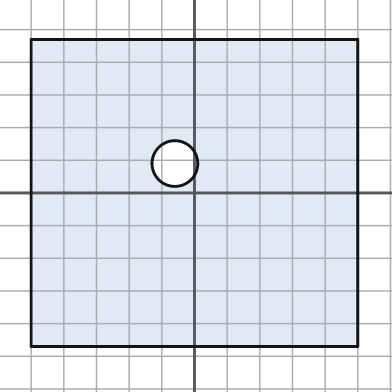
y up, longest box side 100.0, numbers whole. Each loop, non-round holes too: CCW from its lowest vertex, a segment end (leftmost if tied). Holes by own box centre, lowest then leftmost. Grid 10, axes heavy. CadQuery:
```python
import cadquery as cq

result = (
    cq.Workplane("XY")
    .moveTo(-50.0, -47.0)
    .lineTo(50.0, -47.0)
    .lineTo(50.0, 47.0)
    .lineTo(-50.0, 47.0)
    .close()
    .moveTo(-6.0, 9.0)
    .circle(7.0)
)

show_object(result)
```